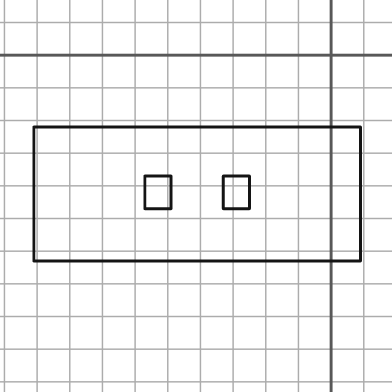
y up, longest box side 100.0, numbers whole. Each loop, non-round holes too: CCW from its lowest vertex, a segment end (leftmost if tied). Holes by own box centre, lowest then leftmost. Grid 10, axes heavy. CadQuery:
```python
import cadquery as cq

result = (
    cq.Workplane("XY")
    .moveTo(-91.0, -63.0)
    .lineTo(9.0, -63.0)
    .lineTo(9.0, -22.0)
    .lineTo(-91.0, -22.0)
    .close()
    .moveTo(-57.0, -47.0)
    .lineTo(-49.0, -47.0)
    .lineTo(-49.0, -37.0)
    .lineTo(-57.0, -37.0)
    .close()
    .moveTo(-33.0, -47.0)
    .lineTo(-25.0, -47.0)
    .lineTo(-25.0, -37.0)
    .lineTo(-33.0, -37.0)
    .close()
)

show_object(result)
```